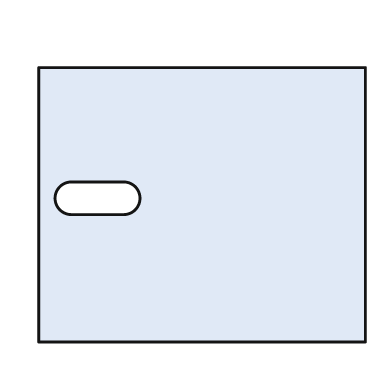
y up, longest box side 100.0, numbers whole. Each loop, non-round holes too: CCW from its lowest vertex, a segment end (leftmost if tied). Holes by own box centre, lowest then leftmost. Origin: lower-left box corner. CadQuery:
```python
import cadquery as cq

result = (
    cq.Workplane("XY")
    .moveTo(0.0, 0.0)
    .lineTo(100.0, 0.0)
    .lineTo(100.0, 84.0)
    .lineTo(0.0, 84.0)
    .close()
    .moveTo(10.0, 39.0)
    .lineTo(26.0, 39.0)
    .threePointArc((31.0, 44.0), (26.0, 49.0))
    .lineTo(10.0, 49.0)
    .threePointArc((5.0, 44.0), (10.0, 39.0))
    .close()
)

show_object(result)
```